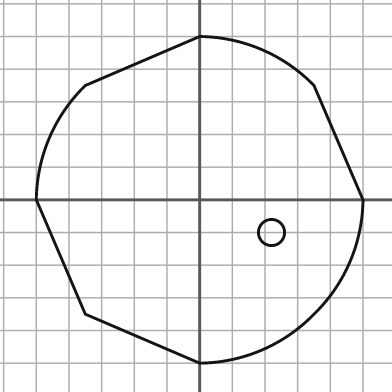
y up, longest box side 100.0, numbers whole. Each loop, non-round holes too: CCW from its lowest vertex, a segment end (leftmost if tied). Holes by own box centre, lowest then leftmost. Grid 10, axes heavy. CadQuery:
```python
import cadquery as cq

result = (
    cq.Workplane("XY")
    .moveTo(0.0, -50.0)
    .threePointArc((19.0, -46.0), (35.0, -35.0))
    .threePointArc((46.0, -19.0), (50.0, 0.0))
    .lineTo(35.0, 35.0)
    .threePointArc((19.0, 46.0), (0.0, 50.0))
    .lineTo(-35.0, 35.0)
    .threePointArc((-46.0, 19.0), (-50.0, 0.0))
    .lineTo(-35.0, -35.0)
    .close()
    .moveTo(22.0, -10.0)
    .circle(4.0)
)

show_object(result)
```